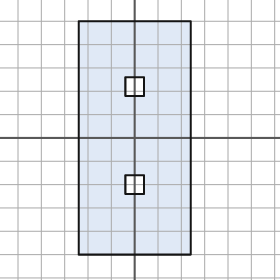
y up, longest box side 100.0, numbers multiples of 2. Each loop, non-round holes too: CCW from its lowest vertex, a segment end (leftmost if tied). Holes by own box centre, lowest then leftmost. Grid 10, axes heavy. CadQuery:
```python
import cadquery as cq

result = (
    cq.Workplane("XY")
    .moveTo(-24.0, -50.0)
    .lineTo(24.0, -50.0)
    .lineTo(24.0, 50.0)
    .lineTo(-24.0, 50.0)
    .close()
    .moveTo(-4.0, -24.0)
    .lineTo(4.0, -24.0)
    .lineTo(4.0, -16.0)
    .lineTo(-4.0, -16.0)
    .close()
    .moveTo(-4.0, 18.0)
    .lineTo(4.0, 18.0)
    .lineTo(4.0, 26.0)
    .lineTo(-4.0, 26.0)
    .close()
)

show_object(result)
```